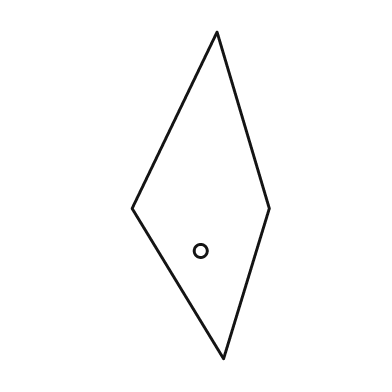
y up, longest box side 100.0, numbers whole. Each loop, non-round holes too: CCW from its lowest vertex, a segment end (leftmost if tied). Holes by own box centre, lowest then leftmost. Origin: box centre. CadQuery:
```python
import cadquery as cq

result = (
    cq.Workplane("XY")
    .moveTo(7.0, -50.0)
    .lineTo(21.0, -4.0)
    .lineTo(5.0, 50.0)
    .lineTo(-21.0, -4.0)
    .close()
    .moveTo(0.0, -17.0)
    .circle(2.0)
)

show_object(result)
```